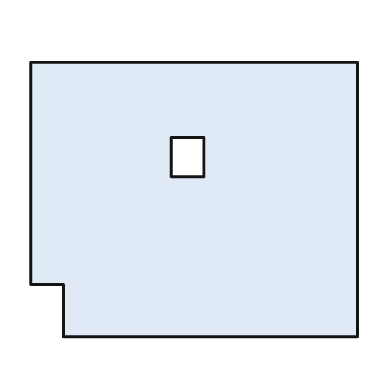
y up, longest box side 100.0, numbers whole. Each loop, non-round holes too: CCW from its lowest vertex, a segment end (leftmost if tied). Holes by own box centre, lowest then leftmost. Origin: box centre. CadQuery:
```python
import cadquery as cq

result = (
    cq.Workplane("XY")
    .moveTo(-40.0, -42.0)
    .lineTo(50.0, -42.0)
    .lineTo(50.0, 42.0)
    .lineTo(-50.0, 42.0)
    .lineTo(-50.0, -26.0)
    .lineTo(-40.0, -26.0)
    .close()
    .moveTo(-7.0, 7.0)
    .lineTo(3.0, 7.0)
    .lineTo(3.0, 19.0)
    .lineTo(-7.0, 19.0)
    .close()
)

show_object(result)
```